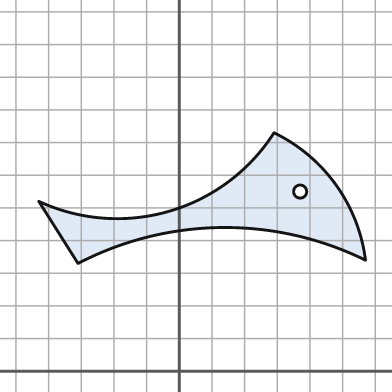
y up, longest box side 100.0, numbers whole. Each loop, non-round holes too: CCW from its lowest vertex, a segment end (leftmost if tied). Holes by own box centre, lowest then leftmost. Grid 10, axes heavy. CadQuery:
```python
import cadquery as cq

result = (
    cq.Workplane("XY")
    .moveTo(-31.0, 33.0)
    .threePointArc((13.0, 44.0), (57.0, 34.0))
    .threePointArc((48.0, 57.0), (29.0, 73.0))
    .threePointArc((-3.0, 49.0), (-43.0, 52.0))
    .close()
    .moveTo(37.0, 55.0)
    .circle(2.0)
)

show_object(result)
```